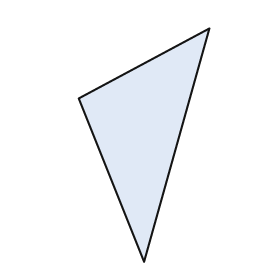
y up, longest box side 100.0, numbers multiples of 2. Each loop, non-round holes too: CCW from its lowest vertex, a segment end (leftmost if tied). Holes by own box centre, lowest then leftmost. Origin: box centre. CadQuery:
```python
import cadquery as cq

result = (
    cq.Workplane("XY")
    .moveTo(0.0, -50.0)
    .lineTo(28.0, 50.0)
    .lineTo(-28.0, 20.0)
    .close()
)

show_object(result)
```